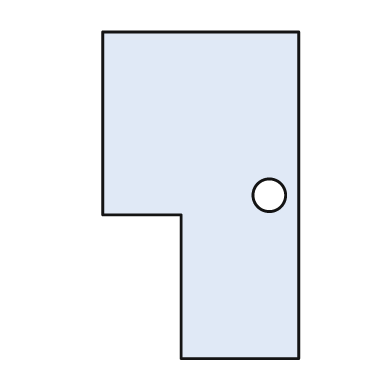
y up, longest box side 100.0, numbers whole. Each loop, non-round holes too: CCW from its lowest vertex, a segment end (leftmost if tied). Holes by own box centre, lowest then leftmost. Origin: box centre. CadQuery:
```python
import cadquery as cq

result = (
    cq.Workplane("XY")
    .moveTo(-6.0, -50.0)
    .lineTo(30.0, -50.0)
    .lineTo(30.0, 50.0)
    .lineTo(-30.0, 50.0)
    .lineTo(-30.0, -6.0)
    .lineTo(-6.0, -6.0)
    .close()
    .moveTo(21.0, 0.0)
    .circle(5.0)
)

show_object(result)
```